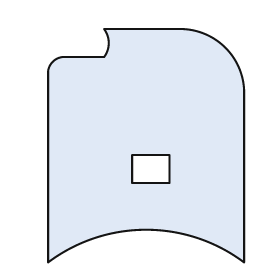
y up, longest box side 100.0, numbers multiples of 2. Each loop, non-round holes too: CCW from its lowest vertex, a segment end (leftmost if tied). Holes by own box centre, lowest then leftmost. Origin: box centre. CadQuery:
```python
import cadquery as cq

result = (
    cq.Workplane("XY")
    .moveTo(-42.0, -50.0)
    .threePointArc((0.0, -36.0), (42.0, -50.0))
    .lineTo(42.0, 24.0)
    .threePointArc((34.0, 42.0), (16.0, 50.0))
    .lineTo(-18.0, 50.0)
    .threePointArc((-16.0, 44.0), (-18.0, 38.0))
    .lineTo(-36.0, 38.0)
    .threePointArc((-40.0, 36.0), (-42.0, 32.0))
    .close()
    .moveTo(-6.0, -16.0)
    .lineTo(10.0, -16.0)
    .lineTo(10.0, -4.0)
    .lineTo(-6.0, -4.0)
    .close()
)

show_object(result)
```